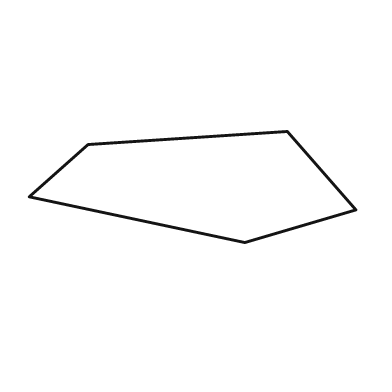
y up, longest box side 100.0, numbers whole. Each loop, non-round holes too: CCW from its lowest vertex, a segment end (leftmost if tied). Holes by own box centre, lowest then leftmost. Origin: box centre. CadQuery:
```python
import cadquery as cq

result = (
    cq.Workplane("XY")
    .moveTo(16.0, -17.0)
    .lineTo(50.0, -7.0)
    .lineTo(29.0, 17.0)
    .lineTo(-32.0, 13.0)
    .lineTo(-50.0, -3.0)
    .close()
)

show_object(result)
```